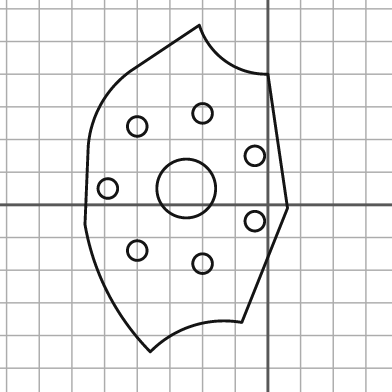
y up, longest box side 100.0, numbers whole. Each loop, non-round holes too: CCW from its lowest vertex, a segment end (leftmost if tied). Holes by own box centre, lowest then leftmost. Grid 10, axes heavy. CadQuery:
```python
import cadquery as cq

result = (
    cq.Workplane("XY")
    .moveTo(-36.0, -45.0)
    .threePointArc((-23.0, -37.0), (-8.0, -36.0))
    .lineTo(6.0, -1.0)
    .lineTo(0.0, 40.0)
    .threePointArc((-13.0, 44.0), (-21.0, 55.0))
    .lineTo(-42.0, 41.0)
    .threePointArc((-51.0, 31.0), (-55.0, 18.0))
    .lineTo(-56.0, -6.0)
    .threePointArc((-49.0, -27.0), (-36.0, -45.0))
    .close()
    .moveTo(-20.0, -18.0)
    .circle(3.0)
    .moveTo(-40.0, -14.0)
    .circle(3.0)
    .moveTo(-4.0, -5.0)
    .circle(3.0)
    .moveTo(-49.0, 5.0)
    .circle(3.0)
    .moveTo(-25.0, 5.0)
    .circle(9.0)
    .moveTo(-4.0, 15.0)
    .circle(3.0)
    .moveTo(-40.0, 24.0)
    .circle(3.0)
    .moveTo(-20.0, 28.0)
    .circle(3.0)
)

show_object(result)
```